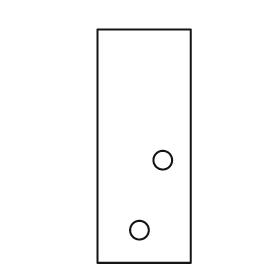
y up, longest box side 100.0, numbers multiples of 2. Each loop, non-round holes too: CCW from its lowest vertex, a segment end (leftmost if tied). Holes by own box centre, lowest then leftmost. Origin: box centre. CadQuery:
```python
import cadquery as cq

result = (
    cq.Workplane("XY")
    .moveTo(-20.0, -50.0)
    .lineTo(20.0, -50.0)
    .lineTo(20.0, 50.0)
    .lineTo(-20.0, 50.0)
    .close()
    .moveTo(-2.0, -36.0)
    .circle(4.0)
    .moveTo(8.0, -6.0)
    .circle(4.0)
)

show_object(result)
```